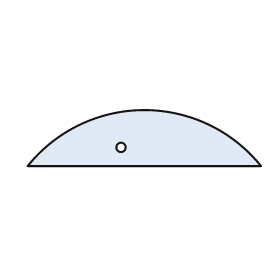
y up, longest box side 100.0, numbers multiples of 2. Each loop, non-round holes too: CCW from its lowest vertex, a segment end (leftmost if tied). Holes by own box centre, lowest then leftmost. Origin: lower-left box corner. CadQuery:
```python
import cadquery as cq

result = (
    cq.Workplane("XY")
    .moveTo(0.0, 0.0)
    .lineTo(100.0, 0.0)
    .threePointArc((50.0, 24.0), (0.0, 0.0))
    .close()
    .moveTo(40.0, 8.0)
    .circle(2.0)
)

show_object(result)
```